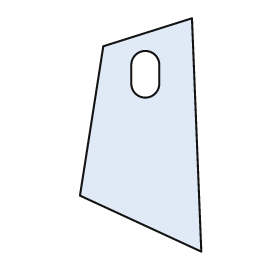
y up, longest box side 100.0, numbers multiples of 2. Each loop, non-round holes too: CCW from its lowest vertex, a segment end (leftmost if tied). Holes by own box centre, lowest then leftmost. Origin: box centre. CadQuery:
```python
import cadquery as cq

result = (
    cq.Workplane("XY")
    .moveTo(26.0, -50.0)
    .lineTo(22.0, 50.0)
    .lineTo(-16.0, 38.0)
    .lineTo(-26.0, -26.0)
    .close()
    .moveTo(-4.0, 22.0)
    .threePointArc((2.0, 16.0), (8.0, 22.0))
    .lineTo(8.0, 30.0)
    .threePointArc((2.0, 36.0), (-4.0, 30.0))
    .close()
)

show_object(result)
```